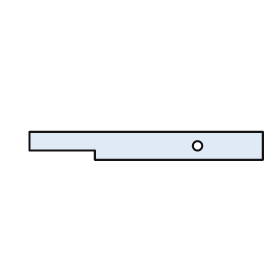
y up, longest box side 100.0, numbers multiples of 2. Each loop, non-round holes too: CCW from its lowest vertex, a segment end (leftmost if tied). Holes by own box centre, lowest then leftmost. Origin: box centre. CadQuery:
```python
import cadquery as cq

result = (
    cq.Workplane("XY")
    .moveTo(-22.0, -6.0)
    .lineTo(50.0, -6.0)
    .lineTo(50.0, 6.0)
    .lineTo(-50.0, 6.0)
    .lineTo(-50.0, -2.0)
    .lineTo(-22.0, -2.0)
    .close()
    .moveTo(22.0, 0.0)
    .circle(2.0)
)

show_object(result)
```